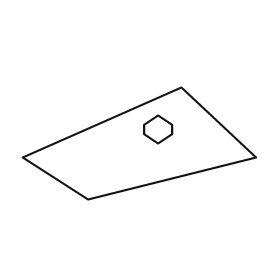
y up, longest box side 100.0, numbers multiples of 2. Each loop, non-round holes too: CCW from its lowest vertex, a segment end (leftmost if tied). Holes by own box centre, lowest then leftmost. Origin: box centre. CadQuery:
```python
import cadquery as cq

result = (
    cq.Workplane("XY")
    .moveTo(-22.0, -24.0)
    .lineTo(50.0, -6.0)
    .lineTo(18.0, 24.0)
    .lineTo(-50.0, -6.0)
    .close()
    .moveTo(8.0, 0.0)
    .lineTo(14.0, 4.0)
    .lineTo(14.0, 8.0)
    .lineTo(8.0, 12.0)
    .lineTo(2.0, 8.0)
    .lineTo(2.0, 4.0)
    .close()
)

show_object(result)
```